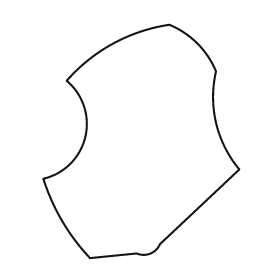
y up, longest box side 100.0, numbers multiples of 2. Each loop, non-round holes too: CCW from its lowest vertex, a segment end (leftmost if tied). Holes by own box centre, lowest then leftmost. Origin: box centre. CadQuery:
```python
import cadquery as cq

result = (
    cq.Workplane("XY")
    .moveTo(-22.0, -50.0)
    .lineTo(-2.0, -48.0)
    .threePointArc((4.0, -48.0), (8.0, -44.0))
    .lineTo(42.0, -12.0)
    .threePointArc((32.0, 8.0), (32.0, 30.0))
    .threePointArc((24.0, 42.0), (12.0, 50.0))
    .threePointArc((-12.0, 42.0), (-32.0, 26.0))
    .threePointArc((-24.0, 2.0), (-42.0, -16.0))
    .threePointArc((-34.0, -34.0), (-22.0, -50.0))
    .close()
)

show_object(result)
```